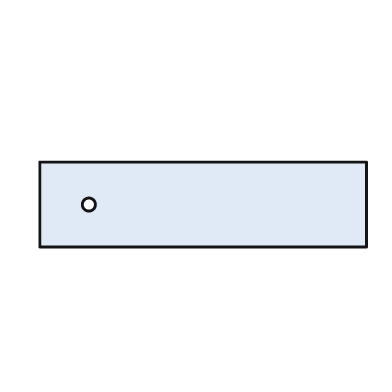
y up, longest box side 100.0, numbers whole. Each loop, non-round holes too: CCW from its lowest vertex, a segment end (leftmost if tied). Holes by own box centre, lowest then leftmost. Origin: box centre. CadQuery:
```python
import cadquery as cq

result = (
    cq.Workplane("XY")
    .moveTo(-50.0, -13.0)
    .lineTo(50.0, -13.0)
    .lineTo(50.0, 13.0)
    .lineTo(-50.0, 13.0)
    .close()
    .moveTo(-35.0, 0.0)
    .circle(2.0)
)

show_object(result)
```